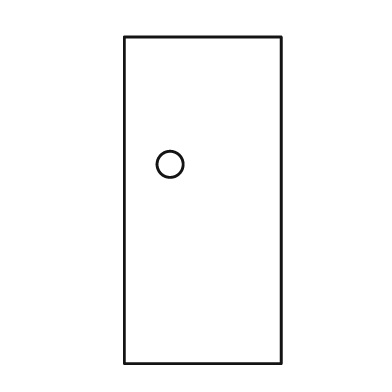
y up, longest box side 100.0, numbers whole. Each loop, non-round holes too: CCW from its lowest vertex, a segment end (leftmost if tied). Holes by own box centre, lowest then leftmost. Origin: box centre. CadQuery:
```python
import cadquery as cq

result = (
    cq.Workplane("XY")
    .moveTo(-24.0, -50.0)
    .lineTo(24.0, -50.0)
    .lineTo(24.0, 50.0)
    .lineTo(-24.0, 50.0)
    .close()
    .moveTo(-10.0, 11.0)
    .circle(4.0)
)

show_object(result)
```